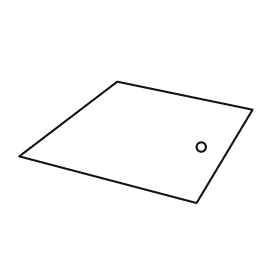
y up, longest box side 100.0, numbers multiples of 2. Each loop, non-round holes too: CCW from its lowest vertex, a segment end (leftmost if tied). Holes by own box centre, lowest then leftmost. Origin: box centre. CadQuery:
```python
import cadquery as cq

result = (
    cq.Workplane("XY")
    .moveTo(26.0, -26.0)
    .lineTo(50.0, 14.0)
    .lineTo(-8.0, 26.0)
    .lineTo(-50.0, -6.0)
    .close()
    .moveTo(28.0, -2.0)
    .circle(2.0)
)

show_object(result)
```